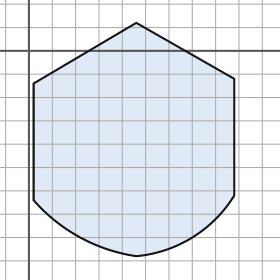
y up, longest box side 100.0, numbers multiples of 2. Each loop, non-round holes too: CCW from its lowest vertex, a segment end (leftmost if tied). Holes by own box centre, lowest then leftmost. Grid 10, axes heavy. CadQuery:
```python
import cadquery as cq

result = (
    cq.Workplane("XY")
    .moveTo(46.0, -88.0)
    .threePointArc((70.0, -80.0), (88.0, -62.0))
    .lineTo(88.0, -12.0)
    .lineTo(46.0, 12.0)
    .lineTo(2.0, -14.0)
    .lineTo(2.0, -64.0)
    .threePointArc((22.0, -80.0), (46.0, -88.0))
    .close()
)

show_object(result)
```